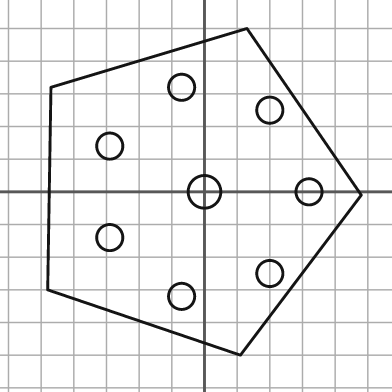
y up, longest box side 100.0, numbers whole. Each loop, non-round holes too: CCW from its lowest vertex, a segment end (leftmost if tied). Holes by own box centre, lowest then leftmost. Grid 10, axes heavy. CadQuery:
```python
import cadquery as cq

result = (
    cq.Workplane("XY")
    .moveTo(11.0, -50.0)
    .lineTo(48.0, -1.0)
    .lineTo(13.0, 50.0)
    .lineTo(-47.0, 32.0)
    .lineTo(-48.0, -30.0)
    .close()
    .moveTo(-7.0, -32.0)
    .circle(4.0)
    .moveTo(20.0, -25.0)
    .circle(4.0)
    .moveTo(-29.0, -14.0)
    .circle(4.0)
    .moveTo(0.0, 0.0)
    .circle(5.0)
    .moveTo(32.0, 0.0)
    .circle(4.0)
    .moveTo(-29.0, 14.0)
    .circle(4.0)
    .moveTo(20.0, 25.0)
    .circle(4.0)
    .moveTo(-7.0, 32.0)
    .circle(4.0)
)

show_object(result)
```